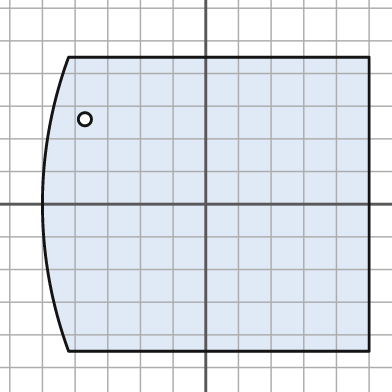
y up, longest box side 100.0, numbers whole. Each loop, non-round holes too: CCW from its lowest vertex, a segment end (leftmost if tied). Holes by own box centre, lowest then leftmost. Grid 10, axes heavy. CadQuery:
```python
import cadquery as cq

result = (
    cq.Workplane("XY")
    .moveTo(-42.0, -45.0)
    .lineTo(50.0, -45.0)
    .lineTo(50.0, 45.0)
    .lineTo(-42.0, 45.0)
    .threePointArc((-50.0, 0.0), (-42.0, -45.0))
    .close()
    .moveTo(-37.0, 26.0)
    .circle(2.0)
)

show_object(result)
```